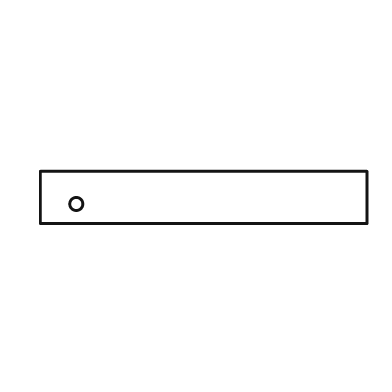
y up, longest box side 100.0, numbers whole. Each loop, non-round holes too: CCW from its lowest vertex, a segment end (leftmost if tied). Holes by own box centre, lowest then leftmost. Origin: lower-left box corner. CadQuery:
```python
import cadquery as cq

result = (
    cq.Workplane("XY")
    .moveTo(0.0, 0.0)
    .lineTo(100.0, 0.0)
    .lineTo(100.0, 16.0)
    .lineTo(0.0, 16.0)
    .close()
    .moveTo(11.0, 6.0)
    .circle(2.0)
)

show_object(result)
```